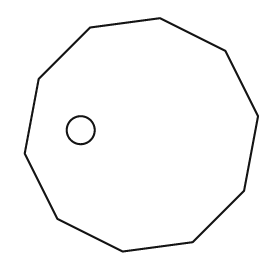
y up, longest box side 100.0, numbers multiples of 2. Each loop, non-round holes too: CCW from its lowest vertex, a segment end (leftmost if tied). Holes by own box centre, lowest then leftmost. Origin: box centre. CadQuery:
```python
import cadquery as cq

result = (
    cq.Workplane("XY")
    .moveTo(-8.0, -50.0)
    .lineTo(22.0, -46.0)
    .lineTo(44.0, -24.0)
    .lineTo(50.0, 8.0)
    .lineTo(36.0, 36.0)
    .lineTo(8.0, 50.0)
    .lineTo(-22.0, 46.0)
    .lineTo(-44.0, 24.0)
    .lineTo(-50.0, -8.0)
    .lineTo(-36.0, -36.0)
    .close()
    .moveTo(-26.0, 2.0)
    .circle(6.0)
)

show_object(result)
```